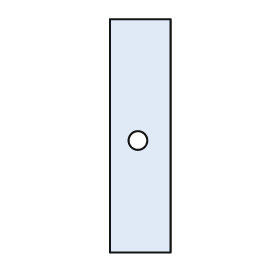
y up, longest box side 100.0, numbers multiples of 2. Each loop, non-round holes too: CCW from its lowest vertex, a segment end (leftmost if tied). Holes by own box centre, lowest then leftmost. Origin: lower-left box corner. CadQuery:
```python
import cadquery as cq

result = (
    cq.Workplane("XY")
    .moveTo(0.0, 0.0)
    .lineTo(26.0, 0.0)
    .lineTo(26.0, 100.0)
    .lineTo(0.0, 100.0)
    .close()
    .moveTo(12.0, 48.0)
    .circle(4.0)
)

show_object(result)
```